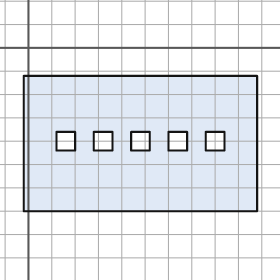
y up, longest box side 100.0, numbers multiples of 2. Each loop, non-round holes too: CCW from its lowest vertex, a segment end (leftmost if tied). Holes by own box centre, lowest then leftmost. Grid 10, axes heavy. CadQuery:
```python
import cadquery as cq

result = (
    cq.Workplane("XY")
    .moveTo(-2.0, -70.0)
    .lineTo(98.0, -70.0)
    .lineTo(98.0, -12.0)
    .lineTo(-2.0, -12.0)
    .close()
    .moveTo(12.0, -44.0)
    .lineTo(20.0, -44.0)
    .lineTo(20.0, -36.0)
    .lineTo(12.0, -36.0)
    .close()
    .moveTo(28.0, -44.0)
    .lineTo(36.0, -44.0)
    .lineTo(36.0, -36.0)
    .lineTo(28.0, -36.0)
    .close()
    .moveTo(44.0, -44.0)
    .lineTo(52.0, -44.0)
    .lineTo(52.0, -36.0)
    .lineTo(44.0, -36.0)
    .close()
    .moveTo(60.0, -44.0)
    .lineTo(68.0, -44.0)
    .lineTo(68.0, -36.0)
    .lineTo(60.0, -36.0)
    .close()
    .moveTo(76.0, -44.0)
    .lineTo(84.0, -44.0)
    .lineTo(84.0, -36.0)
    .lineTo(76.0, -36.0)
    .close()
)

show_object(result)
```